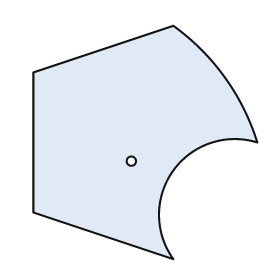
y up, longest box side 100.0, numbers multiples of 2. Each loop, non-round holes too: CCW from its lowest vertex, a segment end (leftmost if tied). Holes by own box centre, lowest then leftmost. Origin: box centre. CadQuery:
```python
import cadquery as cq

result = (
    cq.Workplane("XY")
    .moveTo(12.0, -50.0)
    .threePointArc((12.0, -12.0), (48.0, 0.0))
    .threePointArc((34.0, 28.0), (12.0, 50.0))
    .lineTo(-48.0, 30.0)
    .lineTo(-48.0, -30.0)
    .close()
    .moveTo(-6.0, -8.0)
    .circle(2.0)
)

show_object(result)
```